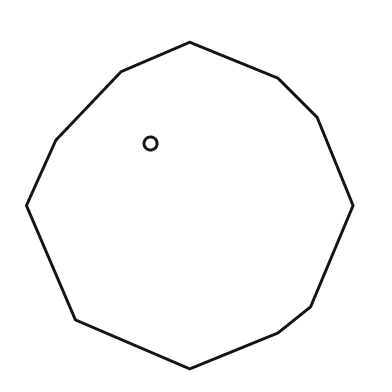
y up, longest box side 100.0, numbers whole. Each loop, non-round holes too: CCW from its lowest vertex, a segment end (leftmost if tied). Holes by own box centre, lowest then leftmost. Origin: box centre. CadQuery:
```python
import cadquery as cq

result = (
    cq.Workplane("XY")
    .moveTo(0.0, -50.0)
    .lineTo(27.0, -39.0)
    .lineTo(37.0, -31.0)
    .lineTo(50.0, 0.0)
    .lineTo(39.0, 27.0)
    .lineTo(27.0, 39.0)
    .lineTo(0.0, 50.0)
    .lineTo(-21.0, 41.0)
    .lineTo(-41.0, 20.0)
    .lineTo(-50.0, 0.0)
    .lineTo(-35.0, -35.0)
    .close()
    .moveTo(-12.0, 19.0)
    .circle(2.0)
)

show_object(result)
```